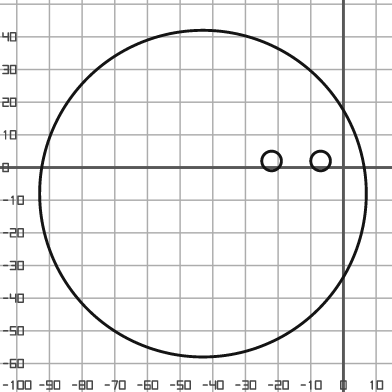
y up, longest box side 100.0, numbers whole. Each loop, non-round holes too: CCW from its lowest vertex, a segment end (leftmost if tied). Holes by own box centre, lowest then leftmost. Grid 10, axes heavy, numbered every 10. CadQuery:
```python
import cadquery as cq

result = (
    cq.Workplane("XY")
    .moveTo(-43.0, -8.0)
    .circle(50.0)
    .moveTo(-22.0, 2.0)
    .circle(3.0)
    .moveTo(-7.0, 2.0)
    .circle(3.0)
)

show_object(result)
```